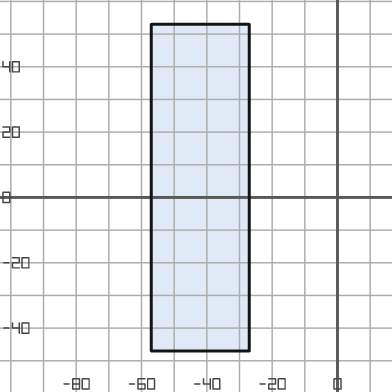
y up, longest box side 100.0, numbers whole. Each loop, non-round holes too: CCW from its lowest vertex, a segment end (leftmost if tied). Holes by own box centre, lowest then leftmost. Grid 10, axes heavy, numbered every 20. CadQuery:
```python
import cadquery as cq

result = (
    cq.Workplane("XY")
    .moveTo(-57.0, -47.0)
    .lineTo(-27.0, -47.0)
    .lineTo(-27.0, 53.0)
    .lineTo(-57.0, 53.0)
    .close()
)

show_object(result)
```